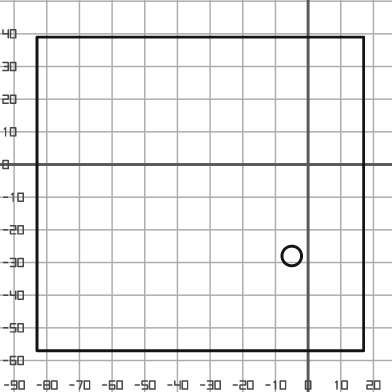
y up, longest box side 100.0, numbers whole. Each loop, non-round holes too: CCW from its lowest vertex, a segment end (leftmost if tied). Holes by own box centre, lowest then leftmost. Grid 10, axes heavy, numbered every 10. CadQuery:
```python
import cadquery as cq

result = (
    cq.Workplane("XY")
    .moveTo(-83.0, -57.0)
    .lineTo(17.0, -57.0)
    .lineTo(17.0, 39.0)
    .lineTo(-83.0, 39.0)
    .close()
    .moveTo(-5.0, -28.0)
    .circle(3.0)
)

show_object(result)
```